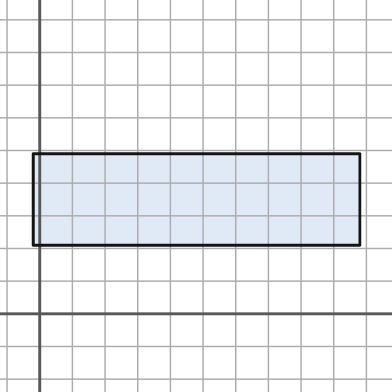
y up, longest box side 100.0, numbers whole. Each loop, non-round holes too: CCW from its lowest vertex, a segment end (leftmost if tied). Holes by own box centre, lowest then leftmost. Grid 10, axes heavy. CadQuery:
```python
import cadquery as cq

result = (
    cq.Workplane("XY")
    .moveTo(-2.0, 21.0)
    .lineTo(98.0, 21.0)
    .lineTo(98.0, 49.0)
    .lineTo(-2.0, 49.0)
    .close()
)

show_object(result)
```